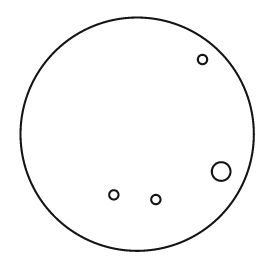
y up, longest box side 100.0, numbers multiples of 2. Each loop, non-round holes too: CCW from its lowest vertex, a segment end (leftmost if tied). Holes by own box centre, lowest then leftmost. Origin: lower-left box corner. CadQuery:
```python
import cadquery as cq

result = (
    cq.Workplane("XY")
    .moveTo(50.0, 50.0)
    .circle(50.0)
    .moveTo(58.0, 22.0)
    .circle(2.0)
    .moveTo(40.0, 24.0)
    .circle(2.0)
    .moveTo(86.0, 34.0)
    .circle(4.0)
    .moveTo(78.0, 82.0)
    .circle(2.0)
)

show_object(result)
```